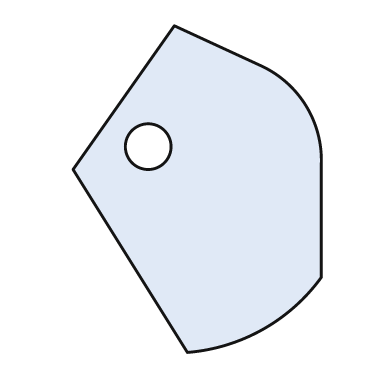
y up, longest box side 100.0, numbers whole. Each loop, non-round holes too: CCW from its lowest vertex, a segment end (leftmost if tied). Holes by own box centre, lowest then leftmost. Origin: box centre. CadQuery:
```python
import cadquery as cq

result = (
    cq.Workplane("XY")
    .moveTo(-3.0, -50.0)
    .threePointArc((20.0, -43.0), (38.0, -27.0))
    .lineTo(38.0, 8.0)
    .threePointArc((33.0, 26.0), (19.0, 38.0))
    .lineTo(-7.0, 50.0)
    .lineTo(-38.0, 6.0)
    .close()
    .moveTo(-15.0, 13.0)
    .circle(7.0)
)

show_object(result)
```